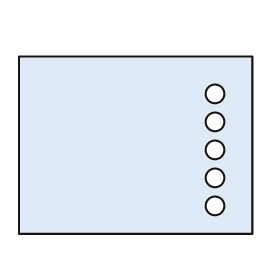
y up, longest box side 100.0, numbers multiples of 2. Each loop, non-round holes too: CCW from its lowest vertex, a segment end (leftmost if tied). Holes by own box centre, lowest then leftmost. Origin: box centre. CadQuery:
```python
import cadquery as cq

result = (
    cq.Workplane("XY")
    .moveTo(-50.0, -38.0)
    .lineTo(50.0, -38.0)
    .lineTo(50.0, 38.0)
    .lineTo(-50.0, 38.0)
    .close()
    .moveTo(34.0, -26.0)
    .circle(4.0)
    .moveTo(34.0, -14.0)
    .circle(4.0)
    .moveTo(34.0, -2.0)
    .circle(4.0)
    .moveTo(34.0, 10.0)
    .circle(4.0)
    .moveTo(34.0, 22.0)
    .circle(4.0)
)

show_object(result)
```